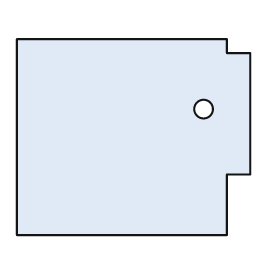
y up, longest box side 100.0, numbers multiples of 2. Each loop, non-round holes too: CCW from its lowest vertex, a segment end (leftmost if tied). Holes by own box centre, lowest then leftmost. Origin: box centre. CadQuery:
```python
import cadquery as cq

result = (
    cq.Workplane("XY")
    .moveTo(-50.0, -42.0)
    .lineTo(40.0, -42.0)
    .lineTo(40.0, -16.0)
    .lineTo(50.0, -16.0)
    .lineTo(50.0, 36.0)
    .lineTo(40.0, 36.0)
    .lineTo(40.0, 42.0)
    .lineTo(-50.0, 42.0)
    .close()
    .moveTo(30.0, 12.0)
    .circle(4.0)
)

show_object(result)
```